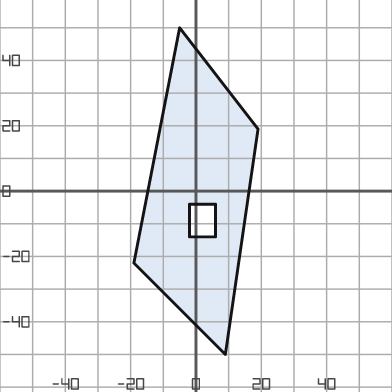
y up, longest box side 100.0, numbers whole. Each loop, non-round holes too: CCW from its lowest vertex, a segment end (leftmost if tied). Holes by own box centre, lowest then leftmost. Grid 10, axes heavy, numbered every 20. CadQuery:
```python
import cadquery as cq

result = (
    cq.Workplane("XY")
    .moveTo(9.0, -50.0)
    .lineTo(19.0, 19.0)
    .lineTo(-5.0, 50.0)
    .lineTo(-19.0, -22.0)
    .close()
    .moveTo(-2.0, -14.0)
    .lineTo(6.0, -14.0)
    .lineTo(6.0, -4.0)
    .lineTo(-2.0, -4.0)
    .close()
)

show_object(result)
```